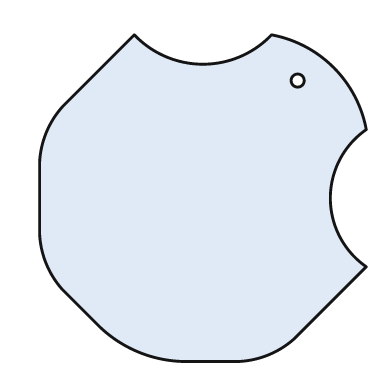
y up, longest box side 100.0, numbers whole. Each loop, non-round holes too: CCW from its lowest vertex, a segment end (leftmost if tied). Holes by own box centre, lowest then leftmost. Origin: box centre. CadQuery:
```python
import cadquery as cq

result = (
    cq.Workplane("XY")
    .moveTo(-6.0, -50.0)
    .lineTo(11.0, -50.0)
    .threePointArc((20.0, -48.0), (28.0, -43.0))
    .lineTo(50.0, -21.0)
    .threePointArc((39.0, 0.0), (50.0, 21.0))
    .threePointArc((40.0, 40.0), (21.0, 50.0))
    .threePointArc((0.0, 41.0), (-21.0, 50.0))
    .lineTo(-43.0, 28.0)
    .threePointArc((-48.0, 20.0), (-50.0, 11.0))
    .lineTo(-50.0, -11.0)
    .threePointArc((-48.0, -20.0), (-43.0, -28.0))
    .lineTo(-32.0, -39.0)
    .threePointArc((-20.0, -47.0), (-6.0, -50.0))
    .close()
    .moveTo(29.0, 36.0)
    .circle(2.0)
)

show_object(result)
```